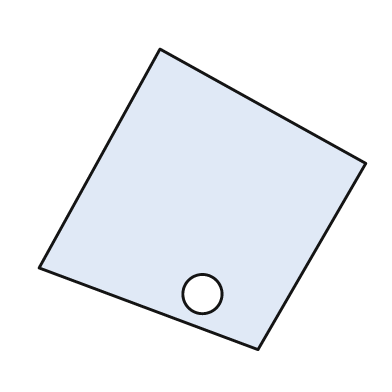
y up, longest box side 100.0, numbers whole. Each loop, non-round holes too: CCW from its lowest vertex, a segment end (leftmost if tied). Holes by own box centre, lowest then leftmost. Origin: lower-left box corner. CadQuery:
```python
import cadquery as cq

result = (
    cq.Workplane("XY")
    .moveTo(67.0, 0.0)
    .lineTo(100.0, 57.0)
    .lineTo(37.0, 92.0)
    .lineTo(0.0, 25.0)
    .close()
    .moveTo(50.0, 17.0)
    .circle(6.0)
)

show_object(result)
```